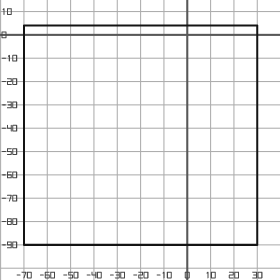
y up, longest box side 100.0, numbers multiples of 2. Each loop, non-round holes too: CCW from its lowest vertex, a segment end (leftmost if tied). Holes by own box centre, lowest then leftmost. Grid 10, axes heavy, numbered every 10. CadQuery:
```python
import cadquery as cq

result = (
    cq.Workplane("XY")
    .moveTo(-70.0, -90.0)
    .lineTo(30.0, -90.0)
    .lineTo(30.0, 4.0)
    .lineTo(-70.0, 4.0)
    .close()
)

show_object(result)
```